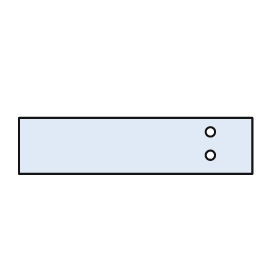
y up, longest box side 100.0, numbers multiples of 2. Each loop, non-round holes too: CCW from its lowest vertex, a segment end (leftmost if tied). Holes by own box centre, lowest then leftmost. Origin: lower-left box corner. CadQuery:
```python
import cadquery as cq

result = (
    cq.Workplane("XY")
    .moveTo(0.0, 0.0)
    .lineTo(100.0, 0.0)
    .lineTo(100.0, 24.0)
    .lineTo(0.0, 24.0)
    .close()
    .moveTo(82.0, 8.0)
    .circle(2.0)
    .moveTo(82.0, 18.0)
    .circle(2.0)
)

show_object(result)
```